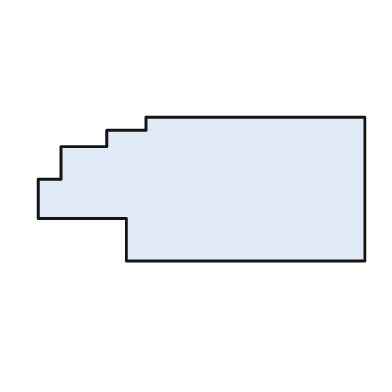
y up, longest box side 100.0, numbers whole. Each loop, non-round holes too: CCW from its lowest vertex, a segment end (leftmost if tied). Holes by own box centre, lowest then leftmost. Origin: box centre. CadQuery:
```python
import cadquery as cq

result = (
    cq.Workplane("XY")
    .moveTo(-23.0, -22.0)
    .lineTo(50.0, -22.0)
    .lineTo(50.0, 22.0)
    .lineTo(-17.0, 22.0)
    .lineTo(-17.0, 18.0)
    .lineTo(-29.0, 18.0)
    .lineTo(-29.0, 13.0)
    .lineTo(-43.0, 13.0)
    .lineTo(-43.0, 3.0)
    .lineTo(-50.0, 3.0)
    .lineTo(-50.0, -9.0)
    .lineTo(-23.0, -9.0)
    .close()
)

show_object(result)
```